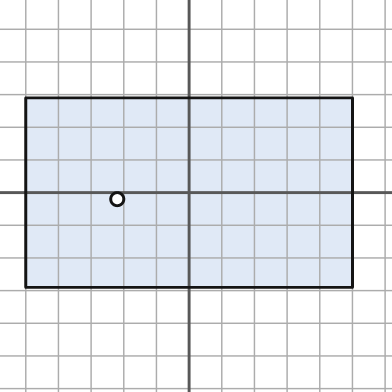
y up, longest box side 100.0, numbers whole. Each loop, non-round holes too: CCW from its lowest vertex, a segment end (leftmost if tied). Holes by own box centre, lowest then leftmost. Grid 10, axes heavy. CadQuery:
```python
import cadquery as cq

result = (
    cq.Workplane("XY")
    .moveTo(-50.0, -29.0)
    .lineTo(50.0, -29.0)
    .lineTo(50.0, 29.0)
    .lineTo(-50.0, 29.0)
    .close()
    .moveTo(-22.0, -2.0)
    .circle(2.0)
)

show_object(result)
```